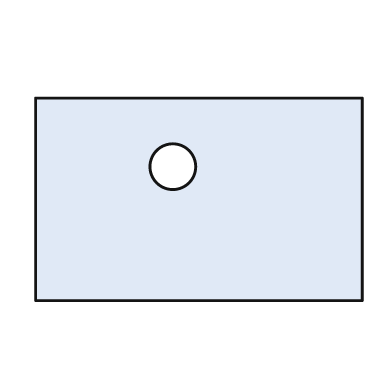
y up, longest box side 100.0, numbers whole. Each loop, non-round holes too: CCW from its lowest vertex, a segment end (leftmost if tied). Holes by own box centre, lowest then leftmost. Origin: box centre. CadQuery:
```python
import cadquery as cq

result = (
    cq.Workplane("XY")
    .moveTo(-50.0, -31.0)
    .lineTo(50.0, -31.0)
    .lineTo(50.0, 31.0)
    .lineTo(-50.0, 31.0)
    .close()
    .moveTo(-8.0, 10.0)
    .circle(7.0)
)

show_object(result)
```